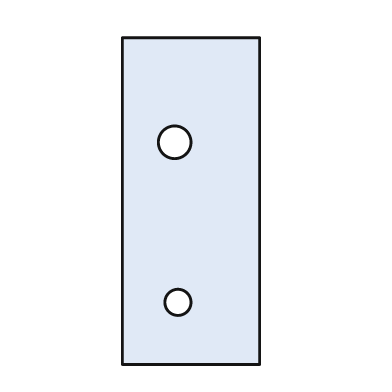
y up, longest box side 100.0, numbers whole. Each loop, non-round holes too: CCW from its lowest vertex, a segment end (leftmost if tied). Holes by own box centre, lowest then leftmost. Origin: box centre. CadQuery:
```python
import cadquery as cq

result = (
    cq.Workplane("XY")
    .moveTo(-21.0, -50.0)
    .lineTo(21.0, -50.0)
    .lineTo(21.0, 50.0)
    .lineTo(-21.0, 50.0)
    .close()
    .moveTo(-4.0, -31.0)
    .circle(4.0)
    .moveTo(-5.0, 18.0)
    .circle(5.0)
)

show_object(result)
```